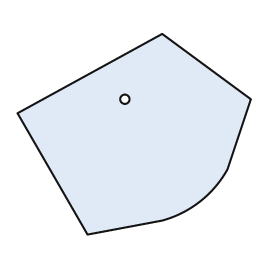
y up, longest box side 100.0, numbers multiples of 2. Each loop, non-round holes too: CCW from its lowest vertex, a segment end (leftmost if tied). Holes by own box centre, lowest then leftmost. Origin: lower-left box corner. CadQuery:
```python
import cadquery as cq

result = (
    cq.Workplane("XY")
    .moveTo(30.0, 0.0)
    .lineTo(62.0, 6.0)
    .threePointArc((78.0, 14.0), (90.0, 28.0))
    .lineTo(100.0, 58.0)
    .lineTo(62.0, 86.0)
    .lineTo(0.0, 52.0)
    .close()
    .moveTo(46.0, 58.0)
    .circle(2.0)
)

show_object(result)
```